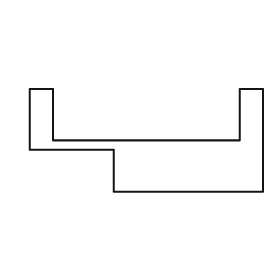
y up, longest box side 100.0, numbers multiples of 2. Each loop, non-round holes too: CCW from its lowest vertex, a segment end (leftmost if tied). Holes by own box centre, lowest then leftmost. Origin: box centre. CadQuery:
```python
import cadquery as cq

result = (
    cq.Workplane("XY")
    .moveTo(-14.0, -22.0)
    .lineTo(50.0, -22.0)
    .lineTo(50.0, 22.0)
    .lineTo(40.0, 22.0)
    .lineTo(40.0, 0.0)
    .lineTo(-40.0, 0.0)
    .lineTo(-40.0, 22.0)
    .lineTo(-50.0, 22.0)
    .lineTo(-50.0, -4.0)
    .lineTo(-14.0, -4.0)
    .close()
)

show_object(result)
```